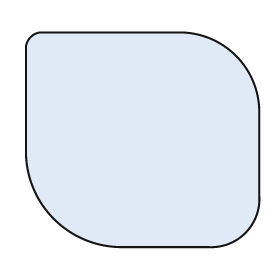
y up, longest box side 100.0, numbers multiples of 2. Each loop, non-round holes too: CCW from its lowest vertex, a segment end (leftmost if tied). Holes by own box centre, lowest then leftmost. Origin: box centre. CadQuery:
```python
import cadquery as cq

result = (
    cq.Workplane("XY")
    .moveTo(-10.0, -46.0)
    .lineTo(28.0, -46.0)
    .threePointArc((44.0, -40.0), (50.0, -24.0))
    .lineTo(50.0, 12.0)
    .threePointArc((40.0, 36.0), (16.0, 46.0))
    .lineTo(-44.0, 46.0)
    .threePointArc((-48.0, 44.0), (-50.0, 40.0))
    .lineTo(-50.0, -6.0)
    .threePointArc((-38.0, -34.0), (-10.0, -46.0))
    .close()
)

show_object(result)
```